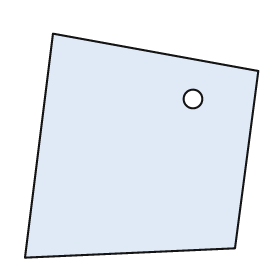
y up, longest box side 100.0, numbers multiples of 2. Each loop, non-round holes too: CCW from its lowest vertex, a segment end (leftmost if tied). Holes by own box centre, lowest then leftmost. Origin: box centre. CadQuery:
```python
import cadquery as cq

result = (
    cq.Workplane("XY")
    .moveTo(-50.0, -48.0)
    .lineTo(40.0, -44.0)
    .lineTo(50.0, 32.0)
    .lineTo(-38.0, 48.0)
    .close()
    .moveTo(22.0, 20.0)
    .circle(4.0)
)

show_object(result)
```